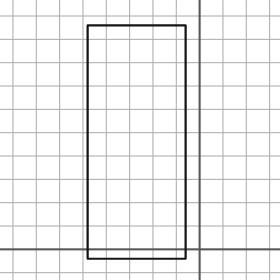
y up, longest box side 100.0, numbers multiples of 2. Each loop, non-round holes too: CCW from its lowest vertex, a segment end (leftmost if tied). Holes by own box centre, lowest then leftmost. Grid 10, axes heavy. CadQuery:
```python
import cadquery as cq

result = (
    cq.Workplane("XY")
    .moveTo(-48.0, -4.0)
    .lineTo(-6.0, -4.0)
    .lineTo(-6.0, 96.0)
    .lineTo(-48.0, 96.0)
    .close()
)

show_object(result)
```